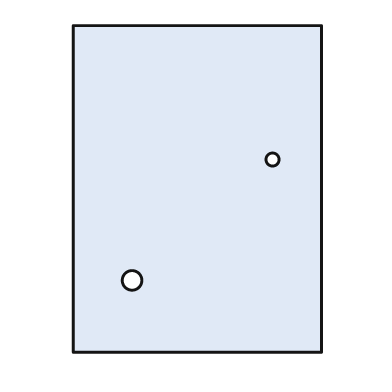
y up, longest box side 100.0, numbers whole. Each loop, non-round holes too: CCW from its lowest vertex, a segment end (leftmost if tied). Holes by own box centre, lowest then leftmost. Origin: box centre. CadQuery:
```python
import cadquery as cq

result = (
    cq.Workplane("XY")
    .moveTo(-38.0, -50.0)
    .lineTo(38.0, -50.0)
    .lineTo(38.0, 50.0)
    .lineTo(-38.0, 50.0)
    .close()
    .moveTo(-20.0, -28.0)
    .circle(3.0)
    .moveTo(23.0, 9.0)
    .circle(2.0)
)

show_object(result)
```